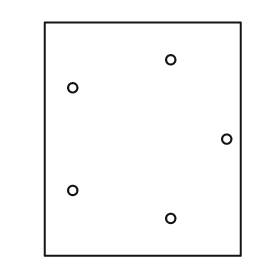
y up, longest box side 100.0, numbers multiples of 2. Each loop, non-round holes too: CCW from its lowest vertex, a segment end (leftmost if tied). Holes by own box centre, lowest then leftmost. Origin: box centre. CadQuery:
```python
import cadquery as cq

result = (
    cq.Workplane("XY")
    .moveTo(-42.0, -50.0)
    .lineTo(42.0, -50.0)
    .lineTo(42.0, 50.0)
    .lineTo(-42.0, 50.0)
    .close()
    .moveTo(12.0, -34.0)
    .circle(2.0)
    .moveTo(-30.0, -22.0)
    .circle(2.0)
    .moveTo(36.0, 0.0)
    .circle(2.0)
    .moveTo(-30.0, 22.0)
    .circle(2.0)
    .moveTo(12.0, 34.0)
    .circle(2.0)
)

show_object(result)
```